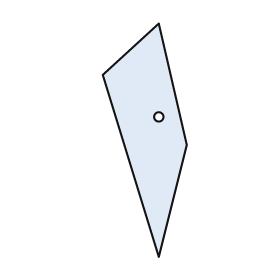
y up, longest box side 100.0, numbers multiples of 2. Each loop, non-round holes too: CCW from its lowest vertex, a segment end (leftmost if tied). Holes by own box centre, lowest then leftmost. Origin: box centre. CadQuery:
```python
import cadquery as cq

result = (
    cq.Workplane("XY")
    .moveTo(6.0, -50.0)
    .lineTo(18.0, -2.0)
    .lineTo(6.0, 50.0)
    .lineTo(-18.0, 28.0)
    .close()
    .moveTo(6.0, 10.0)
    .circle(2.0)
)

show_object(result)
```